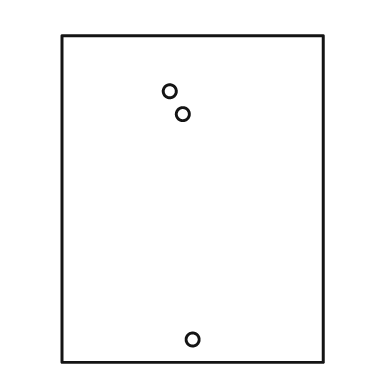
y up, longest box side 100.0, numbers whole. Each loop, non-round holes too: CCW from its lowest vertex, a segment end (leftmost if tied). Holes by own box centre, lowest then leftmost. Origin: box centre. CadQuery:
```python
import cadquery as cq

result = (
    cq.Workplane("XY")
    .moveTo(-40.0, -50.0)
    .lineTo(40.0, -50.0)
    .lineTo(40.0, 50.0)
    .lineTo(-40.0, 50.0)
    .close()
    .moveTo(0.0, -43.0)
    .circle(2.0)
    .moveTo(-3.0, 26.0)
    .circle(2.0)
    .moveTo(-7.0, 33.0)
    .circle(2.0)
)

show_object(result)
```